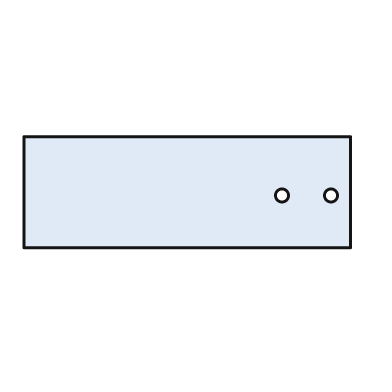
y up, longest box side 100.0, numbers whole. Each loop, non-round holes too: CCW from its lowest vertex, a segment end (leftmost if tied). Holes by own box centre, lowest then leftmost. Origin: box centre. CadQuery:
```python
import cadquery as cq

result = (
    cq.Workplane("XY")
    .moveTo(-50.0, -17.0)
    .lineTo(50.0, -17.0)
    .lineTo(50.0, 17.0)
    .lineTo(-50.0, 17.0)
    .close()
    .moveTo(29.0, -1.0)
    .circle(2.0)
    .moveTo(44.0, -1.0)
    .circle(2.0)
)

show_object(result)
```